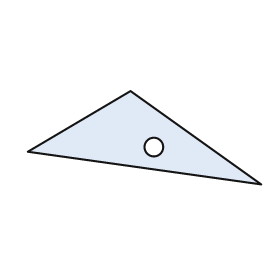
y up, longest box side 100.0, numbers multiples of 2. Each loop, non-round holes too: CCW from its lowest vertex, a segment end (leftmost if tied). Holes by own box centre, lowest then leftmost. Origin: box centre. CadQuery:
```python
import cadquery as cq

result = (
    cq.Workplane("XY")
    .moveTo(50.0, -20.0)
    .lineTo(-6.0, 20.0)
    .lineTo(-50.0, -6.0)
    .close()
    .moveTo(4.0, -4.0)
    .circle(4.0)
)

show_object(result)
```